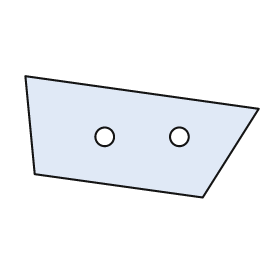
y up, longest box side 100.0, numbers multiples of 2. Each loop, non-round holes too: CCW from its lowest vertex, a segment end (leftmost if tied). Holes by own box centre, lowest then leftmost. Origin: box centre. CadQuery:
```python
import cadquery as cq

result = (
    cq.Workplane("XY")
    .moveTo(26.0, -26.0)
    .lineTo(50.0, 12.0)
    .lineTo(-50.0, 26.0)
    .lineTo(-46.0, -16.0)
    .close()
    .moveTo(-16.0, 0.0)
    .circle(4.0)
    .moveTo(16.0, 0.0)
    .circle(4.0)
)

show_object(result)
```